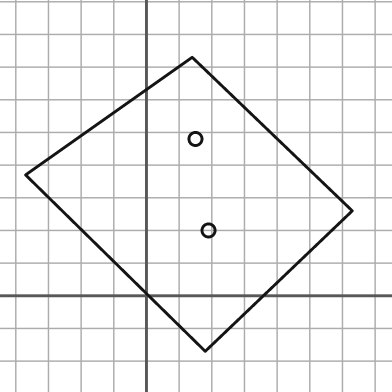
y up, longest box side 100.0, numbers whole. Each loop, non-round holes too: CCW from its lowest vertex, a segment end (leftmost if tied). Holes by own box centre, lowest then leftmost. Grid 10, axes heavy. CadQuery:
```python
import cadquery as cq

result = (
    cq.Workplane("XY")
    .moveTo(18.0, -17.0)
    .lineTo(63.0, 26.0)
    .lineTo(14.0, 73.0)
    .lineTo(-37.0, 37.0)
    .close()
    .moveTo(19.0, 20.0)
    .circle(2.0)
    .moveTo(15.0, 48.0)
    .circle(2.0)
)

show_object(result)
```